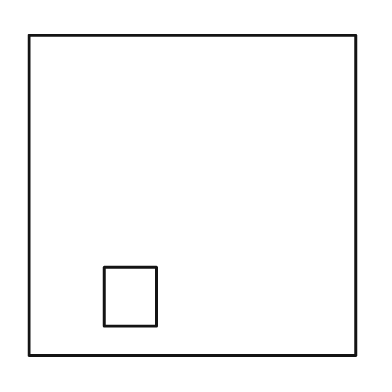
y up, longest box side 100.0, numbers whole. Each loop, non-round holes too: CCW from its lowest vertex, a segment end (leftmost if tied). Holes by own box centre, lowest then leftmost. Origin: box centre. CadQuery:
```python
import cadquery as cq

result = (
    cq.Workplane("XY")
    .moveTo(-50.0, -49.0)
    .lineTo(50.0, -49.0)
    .lineTo(50.0, 49.0)
    .lineTo(-50.0, 49.0)
    .close()
    .moveTo(-27.0, -40.0)
    .lineTo(-11.0, -40.0)
    .lineTo(-11.0, -22.0)
    .lineTo(-27.0, -22.0)
    .close()
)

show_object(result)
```